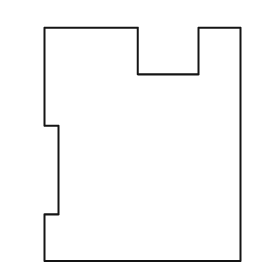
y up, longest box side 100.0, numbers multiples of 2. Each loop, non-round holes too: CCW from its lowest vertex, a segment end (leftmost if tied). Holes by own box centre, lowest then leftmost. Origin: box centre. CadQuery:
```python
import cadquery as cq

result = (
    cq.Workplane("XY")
    .moveTo(-42.0, -50.0)
    .lineTo(42.0, -50.0)
    .lineTo(42.0, 50.0)
    .lineTo(24.0, 50.0)
    .lineTo(24.0, 30.0)
    .lineTo(-2.0, 30.0)
    .lineTo(-2.0, 50.0)
    .lineTo(-42.0, 50.0)
    .lineTo(-42.0, 8.0)
    .lineTo(-36.0, 8.0)
    .lineTo(-36.0, -30.0)
    .lineTo(-42.0, -30.0)
    .close()
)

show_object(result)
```